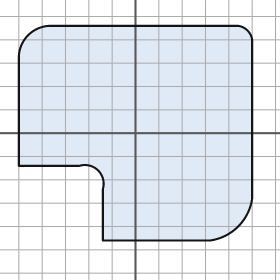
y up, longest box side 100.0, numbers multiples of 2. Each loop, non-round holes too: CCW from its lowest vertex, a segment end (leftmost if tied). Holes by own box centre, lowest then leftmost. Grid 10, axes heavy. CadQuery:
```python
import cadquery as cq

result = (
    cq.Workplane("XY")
    .moveTo(-14.0, -46.0)
    .lineTo(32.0, -46.0)
    .threePointArc((44.0, -40.0), (50.0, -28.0))
    .lineTo(50.0, 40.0)
    .threePointArc((48.0, 44.0), (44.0, 46.0))
    .lineTo(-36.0, 46.0)
    .threePointArc((-46.0, 42.0), (-50.0, 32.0))
    .lineTo(-50.0, -14.0)
    .lineTo(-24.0, -14.0)
    .threePointArc((-16.0, -16.0), (-14.0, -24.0))
    .close()
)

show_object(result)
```